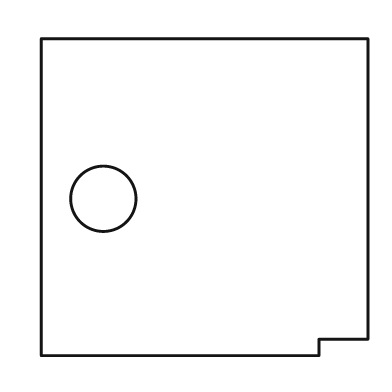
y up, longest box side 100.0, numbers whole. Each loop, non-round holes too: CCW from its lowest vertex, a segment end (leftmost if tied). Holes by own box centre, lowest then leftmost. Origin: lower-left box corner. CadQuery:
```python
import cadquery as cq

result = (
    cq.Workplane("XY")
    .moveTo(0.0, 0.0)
    .lineTo(85.0, 0.0)
    .lineTo(85.0, 5.0)
    .lineTo(100.0, 5.0)
    .lineTo(100.0, 97.0)
    .lineTo(0.0, 97.0)
    .close()
    .moveTo(19.0, 48.0)
    .circle(10.0)
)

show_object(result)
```